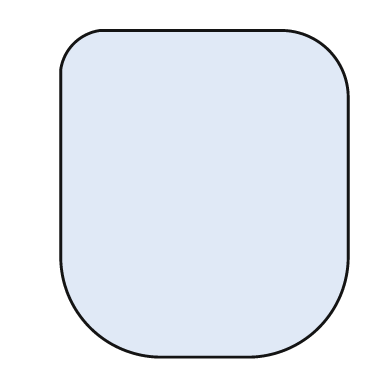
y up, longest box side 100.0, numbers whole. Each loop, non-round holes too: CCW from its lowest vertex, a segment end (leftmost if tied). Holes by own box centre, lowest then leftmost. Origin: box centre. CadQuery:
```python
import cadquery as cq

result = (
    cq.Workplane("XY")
    .moveTo(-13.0, -50.0)
    .lineTo(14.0, -50.0)
    .threePointArc((35.0, -41.0), (44.0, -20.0))
    .lineTo(44.0, 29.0)
    .threePointArc((38.0, 44.0), (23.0, 50.0))
    .lineTo(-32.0, 50.0)
    .threePointArc((-40.0, 46.0), (-44.0, 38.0))
    .lineTo(-44.0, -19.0)
    .threePointArc((-35.0, -41.0), (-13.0, -50.0))
    .close()
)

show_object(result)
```